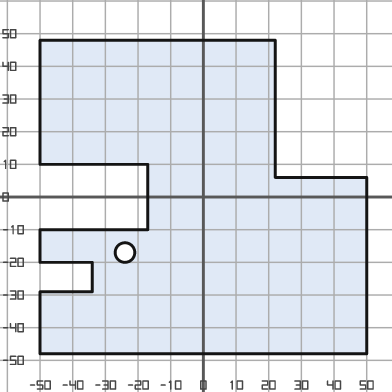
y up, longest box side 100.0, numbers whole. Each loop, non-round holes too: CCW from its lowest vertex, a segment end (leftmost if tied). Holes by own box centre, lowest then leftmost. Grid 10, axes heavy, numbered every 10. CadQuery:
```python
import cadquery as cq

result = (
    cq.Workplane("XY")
    .moveTo(-50.0, -48.0)
    .lineTo(50.0, -48.0)
    .lineTo(50.0, 6.0)
    .lineTo(22.0, 6.0)
    .lineTo(22.0, 48.0)
    .lineTo(-50.0, 48.0)
    .lineTo(-50.0, 10.0)
    .lineTo(-17.0, 10.0)
    .lineTo(-17.0, -10.0)
    .lineTo(-50.0, -10.0)
    .lineTo(-50.0, -20.0)
    .lineTo(-34.0, -20.0)
    .lineTo(-34.0, -29.0)
    .lineTo(-50.0, -29.0)
    .close()
    .moveTo(-24.0, -17.0)
    .circle(3.0)
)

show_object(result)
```